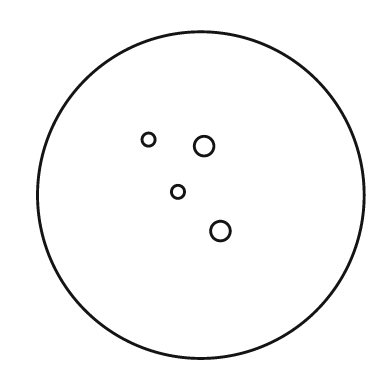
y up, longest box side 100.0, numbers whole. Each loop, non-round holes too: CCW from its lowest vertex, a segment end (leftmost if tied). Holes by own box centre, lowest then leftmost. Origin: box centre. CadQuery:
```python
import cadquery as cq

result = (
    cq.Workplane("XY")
    .moveTo(0.0, 0.0)
    .circle(50.0)
    .moveTo(6.0, -11.0)
    .circle(3.0)
    .moveTo(-7.0, 1.0)
    .circle(2.0)
    .moveTo(1.0, 15.0)
    .circle(3.0)
    .moveTo(-16.0, 17.0)
    .circle(2.0)
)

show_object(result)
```